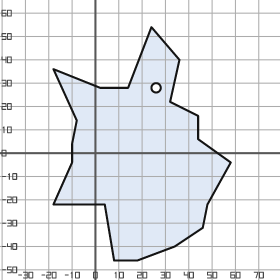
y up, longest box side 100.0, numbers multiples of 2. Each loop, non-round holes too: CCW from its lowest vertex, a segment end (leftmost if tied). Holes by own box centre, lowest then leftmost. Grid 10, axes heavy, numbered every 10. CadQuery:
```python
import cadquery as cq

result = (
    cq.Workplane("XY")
    .moveTo(8.0, -46.0)
    .lineTo(18.0, -46.0)
    .lineTo(34.0, -40.0)
    .lineTo(46.0, -32.0)
    .lineTo(48.0, -22.0)
    .lineTo(58.0, -4.0)
    .lineTo(44.0, 6.0)
    .lineTo(44.0, 16.0)
    .lineTo(32.0, 22.0)
    .lineTo(36.0, 40.0)
    .lineTo(24.0, 54.0)
    .lineTo(14.0, 28.0)
    .lineTo(2.0, 28.0)
    .lineTo(-18.0, 36.0)
    .lineTo(-8.0, 14.0)
    .lineTo(-10.0, 4.0)
    .lineTo(-10.0, -4.0)
    .lineTo(-18.0, -22.0)
    .lineTo(4.0, -22.0)
    .close()
    .moveTo(26.0, 28.0)
    .circle(2.0)
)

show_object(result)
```